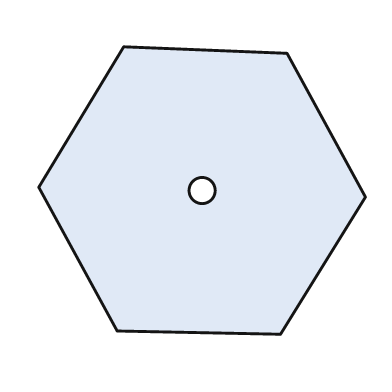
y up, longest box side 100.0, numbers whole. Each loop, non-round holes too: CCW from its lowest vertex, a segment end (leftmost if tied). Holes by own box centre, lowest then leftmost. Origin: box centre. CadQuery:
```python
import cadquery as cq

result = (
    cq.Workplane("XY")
    .moveTo(24.0, -44.0)
    .lineTo(50.0, -2.0)
    .lineTo(26.0, 42.0)
    .lineTo(-24.0, 44.0)
    .lineTo(-50.0, 1.0)
    .lineTo(-26.0, -43.0)
    .close()
    .moveTo(0.0, 0.0)
    .circle(4.0)
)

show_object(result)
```